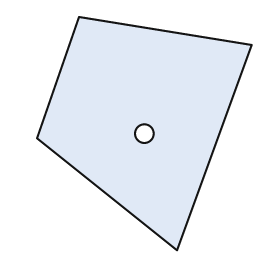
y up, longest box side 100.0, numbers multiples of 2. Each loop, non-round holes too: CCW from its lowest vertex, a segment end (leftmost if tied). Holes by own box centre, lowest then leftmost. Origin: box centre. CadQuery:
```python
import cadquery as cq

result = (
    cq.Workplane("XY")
    .moveTo(14.0, -50.0)
    .lineTo(46.0, 38.0)
    .lineTo(-28.0, 50.0)
    .lineTo(-46.0, -2.0)
    .close()
    .moveTo(0.0, 0.0)
    .circle(4.0)
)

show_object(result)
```